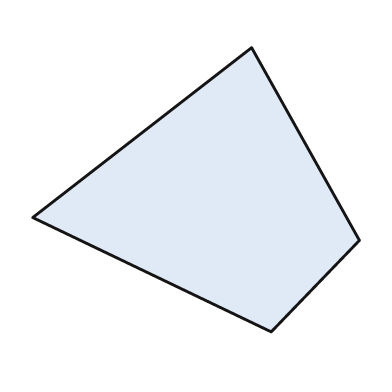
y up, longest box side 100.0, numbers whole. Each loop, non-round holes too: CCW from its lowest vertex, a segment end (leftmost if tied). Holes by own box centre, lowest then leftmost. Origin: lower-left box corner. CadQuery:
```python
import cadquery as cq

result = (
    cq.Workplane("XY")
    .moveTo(73.0, 0.0)
    .lineTo(100.0, 28.0)
    .lineTo(67.0, 87.0)
    .lineTo(0.0, 35.0)
    .close()
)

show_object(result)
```